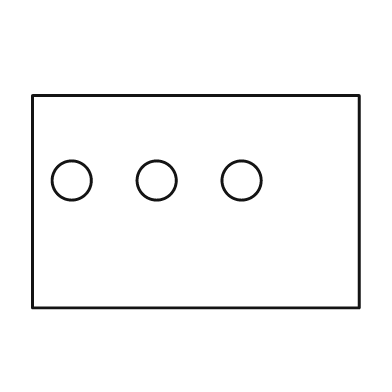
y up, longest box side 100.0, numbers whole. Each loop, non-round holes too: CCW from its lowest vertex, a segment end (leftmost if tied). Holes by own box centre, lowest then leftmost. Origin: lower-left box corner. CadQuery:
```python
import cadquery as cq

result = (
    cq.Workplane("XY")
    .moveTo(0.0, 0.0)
    .lineTo(100.0, 0.0)
    .lineTo(100.0, 65.0)
    .lineTo(0.0, 65.0)
    .close()
    .moveTo(12.0, 39.0)
    .circle(6.0)
    .moveTo(38.0, 39.0)
    .circle(6.0)
    .moveTo(64.0, 39.0)
    .circle(6.0)
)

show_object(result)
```